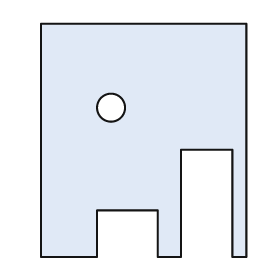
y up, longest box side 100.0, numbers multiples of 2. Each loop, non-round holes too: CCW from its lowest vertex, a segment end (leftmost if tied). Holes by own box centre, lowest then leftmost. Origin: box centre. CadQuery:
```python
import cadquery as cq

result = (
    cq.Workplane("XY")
    .moveTo(-44.0, -50.0)
    .lineTo(-20.0, -50.0)
    .lineTo(-20.0, -30.0)
    .lineTo(6.0, -30.0)
    .lineTo(6.0, -50.0)
    .lineTo(16.0, -50.0)
    .lineTo(16.0, -4.0)
    .lineTo(38.0, -4.0)
    .lineTo(38.0, -50.0)
    .lineTo(44.0, -50.0)
    .lineTo(44.0, 50.0)
    .lineTo(-44.0, 50.0)
    .close()
    .moveTo(-14.0, 14.0)
    .circle(6.0)
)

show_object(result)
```